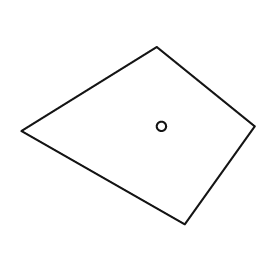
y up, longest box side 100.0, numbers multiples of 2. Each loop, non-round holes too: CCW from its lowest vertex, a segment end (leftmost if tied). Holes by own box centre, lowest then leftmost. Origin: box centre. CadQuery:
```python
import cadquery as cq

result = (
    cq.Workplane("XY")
    .moveTo(20.0, -38.0)
    .lineTo(50.0, 4.0)
    .lineTo(8.0, 38.0)
    .lineTo(-50.0, 2.0)
    .close()
    .moveTo(10.0, 4.0)
    .circle(2.0)
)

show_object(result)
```